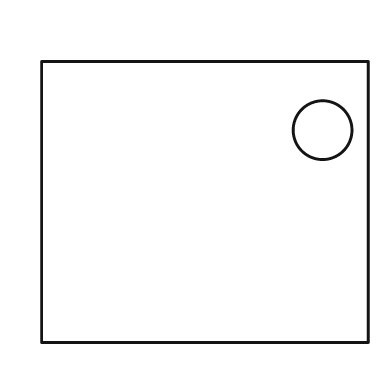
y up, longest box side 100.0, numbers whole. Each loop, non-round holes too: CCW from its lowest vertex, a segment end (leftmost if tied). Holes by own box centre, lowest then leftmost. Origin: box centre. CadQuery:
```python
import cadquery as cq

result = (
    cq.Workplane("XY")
    .moveTo(-50.0, -43.0)
    .lineTo(50.0, -43.0)
    .lineTo(50.0, 43.0)
    .lineTo(-50.0, 43.0)
    .close()
    .moveTo(36.0, 22.0)
    .circle(9.0)
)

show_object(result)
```